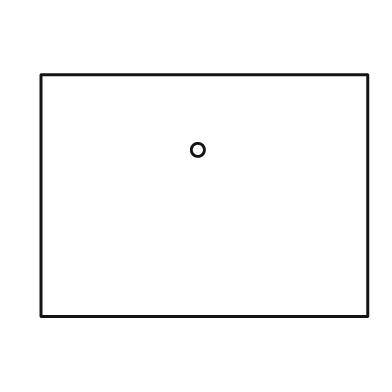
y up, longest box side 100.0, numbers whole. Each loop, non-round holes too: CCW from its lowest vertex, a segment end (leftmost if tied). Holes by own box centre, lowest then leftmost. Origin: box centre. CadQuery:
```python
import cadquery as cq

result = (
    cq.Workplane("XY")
    .moveTo(-50.0, -37.0)
    .lineTo(50.0, -37.0)
    .lineTo(50.0, 37.0)
    .lineTo(-50.0, 37.0)
    .close()
    .moveTo(-2.0, 14.0)
    .circle(2.0)
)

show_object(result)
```